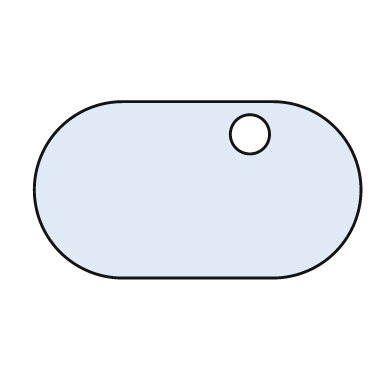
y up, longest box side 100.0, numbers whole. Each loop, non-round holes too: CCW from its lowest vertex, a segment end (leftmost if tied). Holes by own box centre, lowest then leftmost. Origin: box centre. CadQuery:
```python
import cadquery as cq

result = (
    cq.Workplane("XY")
    .moveTo(-23.0, -27.0)
    .lineTo(23.0, -27.0)
    .threePointArc((50.0, 0.0), (23.0, 27.0))
    .lineTo(-23.0, 27.0)
    .threePointArc((-50.0, 0.0), (-23.0, -27.0))
    .close()
    .moveTo(16.0, 17.0)
    .circle(6.0)
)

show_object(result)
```